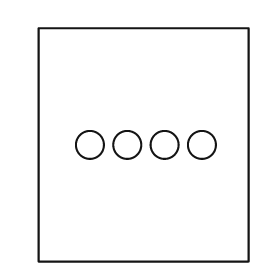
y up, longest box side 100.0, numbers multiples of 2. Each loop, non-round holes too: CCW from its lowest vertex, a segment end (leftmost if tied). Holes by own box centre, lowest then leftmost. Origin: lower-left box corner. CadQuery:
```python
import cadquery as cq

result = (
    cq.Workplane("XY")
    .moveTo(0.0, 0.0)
    .lineTo(90.0, 0.0)
    .lineTo(90.0, 100.0)
    .lineTo(0.0, 100.0)
    .close()
    .moveTo(22.0, 50.0)
    .circle(6.0)
    .moveTo(38.0, 50.0)
    .circle(6.0)
    .moveTo(54.0, 50.0)
    .circle(6.0)
    .moveTo(70.0, 50.0)
    .circle(6.0)
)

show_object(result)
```